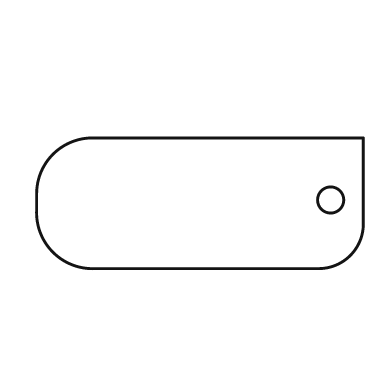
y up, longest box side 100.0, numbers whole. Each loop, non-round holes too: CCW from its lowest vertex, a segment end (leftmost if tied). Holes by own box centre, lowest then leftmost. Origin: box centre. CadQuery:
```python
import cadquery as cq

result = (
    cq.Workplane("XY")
    .moveTo(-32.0, -20.0)
    .lineTo(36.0, -20.0)
    .threePointArc((46.0, -16.0), (50.0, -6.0))
    .lineTo(50.0, 20.0)
    .lineTo(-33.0, 20.0)
    .threePointArc((-45.0, 15.0), (-50.0, 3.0))
    .lineTo(-50.0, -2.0)
    .threePointArc((-45.0, -15.0), (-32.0, -20.0))
    .close()
    .moveTo(40.0, 1.0)
    .circle(4.0)
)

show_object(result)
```